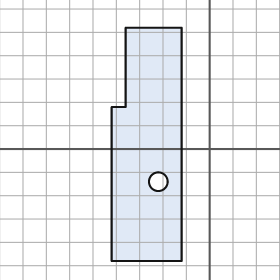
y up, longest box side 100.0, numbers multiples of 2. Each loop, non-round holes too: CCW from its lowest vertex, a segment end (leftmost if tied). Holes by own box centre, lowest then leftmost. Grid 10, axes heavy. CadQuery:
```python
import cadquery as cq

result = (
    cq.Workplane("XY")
    .moveTo(-42.0, -48.0)
    .lineTo(-12.0, -48.0)
    .lineTo(-12.0, 52.0)
    .lineTo(-36.0, 52.0)
    .lineTo(-36.0, 18.0)
    .lineTo(-42.0, 18.0)
    .close()
    .moveTo(-22.0, -14.0)
    .circle(4.0)
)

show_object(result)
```